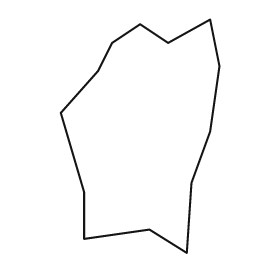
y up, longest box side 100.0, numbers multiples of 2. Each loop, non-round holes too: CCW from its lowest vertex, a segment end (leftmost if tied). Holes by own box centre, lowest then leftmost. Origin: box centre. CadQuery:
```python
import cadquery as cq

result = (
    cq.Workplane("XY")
    .moveTo(20.0, -50.0)
    .lineTo(22.0, -20.0)
    .lineTo(30.0, 2.0)
    .lineTo(34.0, 30.0)
    .lineTo(30.0, 50.0)
    .lineTo(12.0, 40.0)
    .lineTo(0.0, 48.0)
    .lineTo(-12.0, 40.0)
    .lineTo(-18.0, 28.0)
    .lineTo(-34.0, 10.0)
    .lineTo(-24.0, -24.0)
    .lineTo(-24.0, -44.0)
    .lineTo(4.0, -40.0)
    .close()
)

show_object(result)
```